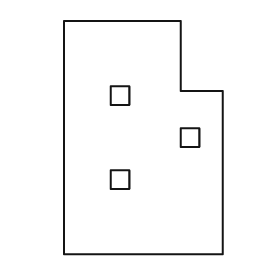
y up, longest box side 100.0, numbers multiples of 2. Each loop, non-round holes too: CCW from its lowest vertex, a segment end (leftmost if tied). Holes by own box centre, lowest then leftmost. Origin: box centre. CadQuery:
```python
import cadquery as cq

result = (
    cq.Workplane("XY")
    .moveTo(-34.0, -50.0)
    .lineTo(34.0, -50.0)
    .lineTo(34.0, 20.0)
    .lineTo(16.0, 20.0)
    .lineTo(16.0, 50.0)
    .lineTo(-34.0, 50.0)
    .close()
    .moveTo(-14.0, -22.0)
    .lineTo(-6.0, -22.0)
    .lineTo(-6.0, -14.0)
    .lineTo(-14.0, -14.0)
    .close()
    .moveTo(16.0, -4.0)
    .lineTo(24.0, -4.0)
    .lineTo(24.0, 4.0)
    .lineTo(16.0, 4.0)
    .close()
    .moveTo(-14.0, 14.0)
    .lineTo(-6.0, 14.0)
    .lineTo(-6.0, 22.0)
    .lineTo(-14.0, 22.0)
    .close()
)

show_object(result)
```